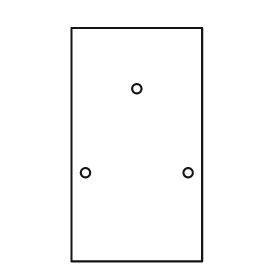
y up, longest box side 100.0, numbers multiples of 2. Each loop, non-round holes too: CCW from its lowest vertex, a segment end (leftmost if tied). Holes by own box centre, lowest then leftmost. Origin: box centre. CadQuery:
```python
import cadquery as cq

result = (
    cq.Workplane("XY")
    .moveTo(-28.0, -50.0)
    .lineTo(28.0, -50.0)
    .lineTo(28.0, 50.0)
    .lineTo(-28.0, 50.0)
    .close()
    .moveTo(-22.0, -12.0)
    .circle(2.0)
    .moveTo(22.0, -12.0)
    .circle(2.0)
    .moveTo(0.0, 24.0)
    .circle(2.0)
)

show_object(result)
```